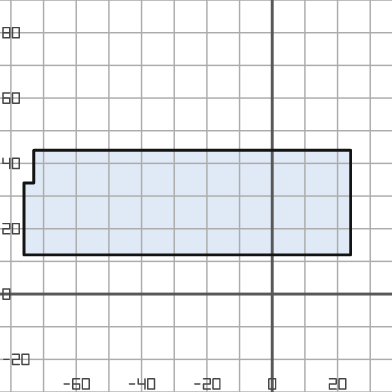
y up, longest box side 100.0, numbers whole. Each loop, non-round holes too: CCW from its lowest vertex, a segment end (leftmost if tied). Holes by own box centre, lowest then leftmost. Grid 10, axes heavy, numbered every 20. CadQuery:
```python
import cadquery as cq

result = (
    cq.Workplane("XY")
    .moveTo(-76.0, 12.0)
    .lineTo(24.0, 12.0)
    .lineTo(24.0, 44.0)
    .lineTo(-73.0, 44.0)
    .lineTo(-73.0, 34.0)
    .lineTo(-76.0, 34.0)
    .close()
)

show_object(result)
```